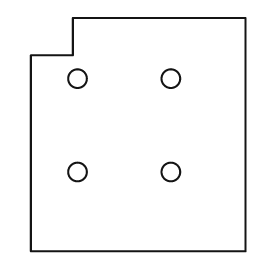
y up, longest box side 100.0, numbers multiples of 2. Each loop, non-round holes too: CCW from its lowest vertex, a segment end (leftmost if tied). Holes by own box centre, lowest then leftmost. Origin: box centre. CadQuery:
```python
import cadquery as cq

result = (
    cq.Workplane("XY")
    .moveTo(-46.0, -50.0)
    .lineTo(46.0, -50.0)
    .lineTo(46.0, 50.0)
    .lineTo(-28.0, 50.0)
    .lineTo(-28.0, 34.0)
    .lineTo(-46.0, 34.0)
    .close()
    .moveTo(-26.0, -16.0)
    .circle(4.0)
    .moveTo(14.0, -16.0)
    .circle(4.0)
    .moveTo(-26.0, 24.0)
    .circle(4.0)
    .moveTo(14.0, 24.0)
    .circle(4.0)
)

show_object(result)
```